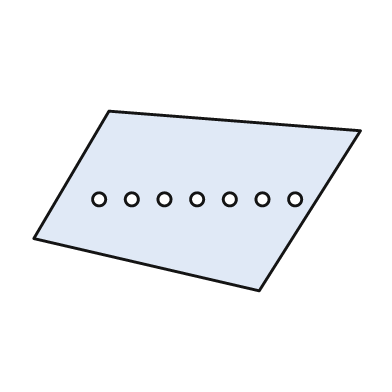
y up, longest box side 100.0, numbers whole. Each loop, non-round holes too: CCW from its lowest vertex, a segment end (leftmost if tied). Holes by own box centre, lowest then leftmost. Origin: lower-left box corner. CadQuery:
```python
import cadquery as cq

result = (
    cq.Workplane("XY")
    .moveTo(69.0, 0.0)
    .lineTo(100.0, 49.0)
    .lineTo(23.0, 55.0)
    .lineTo(0.0, 16.0)
    .close()
    .moveTo(20.0, 28.0)
    .circle(2.0)
    .moveTo(30.0, 28.0)
    .circle(2.0)
    .moveTo(40.0, 28.0)
    .circle(2.0)
    .moveTo(50.0, 28.0)
    .circle(2.0)
    .moveTo(60.0, 28.0)
    .circle(2.0)
    .moveTo(70.0, 28.0)
    .circle(2.0)
    .moveTo(80.0, 28.0)
    .circle(2.0)
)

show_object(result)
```